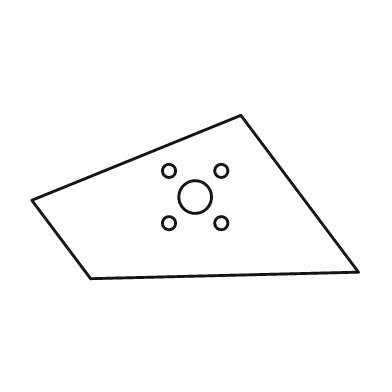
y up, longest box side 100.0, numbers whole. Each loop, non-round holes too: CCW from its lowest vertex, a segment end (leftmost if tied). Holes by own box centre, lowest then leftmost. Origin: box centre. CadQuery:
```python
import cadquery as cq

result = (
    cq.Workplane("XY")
    .moveTo(-32.0, -25.0)
    .lineTo(50.0, -23.0)
    .lineTo(14.0, 25.0)
    .lineTo(-50.0, -1.0)
    .close()
    .moveTo(-8.0, -8.0)
    .circle(2.0)
    .moveTo(8.0, -8.0)
    .circle(2.0)
    .moveTo(0.0, 0.0)
    .circle(5.0)
    .moveTo(-8.0, 8.0)
    .circle(2.0)
    .moveTo(8.0, 8.0)
    .circle(2.0)
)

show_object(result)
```